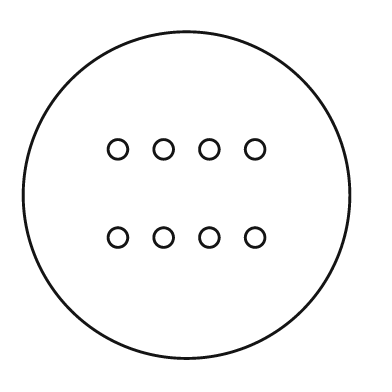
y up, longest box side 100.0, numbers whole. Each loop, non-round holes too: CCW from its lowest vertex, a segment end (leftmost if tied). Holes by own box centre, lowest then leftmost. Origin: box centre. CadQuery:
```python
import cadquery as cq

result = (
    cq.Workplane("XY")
    .moveTo(0.0, 0.0)
    .circle(50.0)
    .moveTo(-21.0, -13.0)
    .circle(3.0)
    .moveTo(-7.0, -13.0)
    .circle(3.0)
    .moveTo(7.0, -13.0)
    .circle(3.0)
    .moveTo(21.0, -13.0)
    .circle(3.0)
    .moveTo(-21.0, 14.0)
    .circle(3.0)
    .moveTo(-7.0, 14.0)
    .circle(3.0)
    .moveTo(7.0, 14.0)
    .circle(3.0)
    .moveTo(21.0, 14.0)
    .circle(3.0)
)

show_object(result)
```